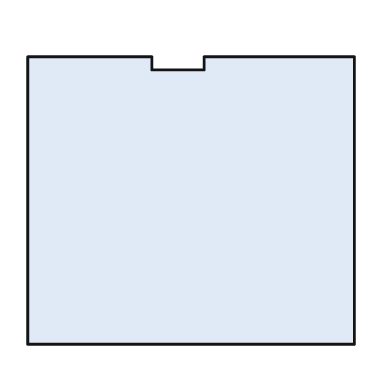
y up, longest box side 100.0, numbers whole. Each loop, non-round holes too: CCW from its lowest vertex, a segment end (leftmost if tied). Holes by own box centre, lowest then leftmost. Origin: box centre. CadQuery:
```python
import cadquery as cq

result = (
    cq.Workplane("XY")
    .moveTo(-50.0, -44.0)
    .lineTo(50.0, -44.0)
    .lineTo(50.0, 44.0)
    .lineTo(4.0, 44.0)
    .lineTo(4.0, 40.0)
    .lineTo(-12.0, 40.0)
    .lineTo(-12.0, 44.0)
    .lineTo(-50.0, 44.0)
    .close()
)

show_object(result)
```